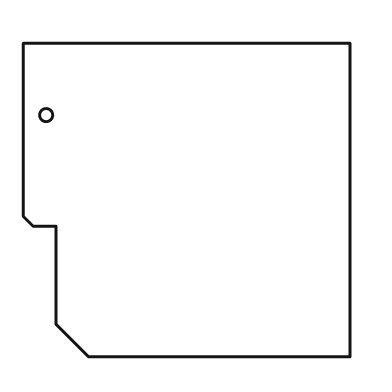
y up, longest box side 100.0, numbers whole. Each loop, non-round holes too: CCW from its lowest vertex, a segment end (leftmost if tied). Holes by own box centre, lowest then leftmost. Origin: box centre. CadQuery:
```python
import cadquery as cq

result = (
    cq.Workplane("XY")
    .moveTo(-30.0, -48.0)
    .lineTo(50.0, -48.0)
    .lineTo(50.0, 48.0)
    .lineTo(-50.0, 48.0)
    .lineTo(-50.0, -5.0)
    .lineTo(-47.0, -8.0)
    .lineTo(-40.0, -8.0)
    .lineTo(-40.0, -38.0)
    .close()
    .moveTo(-43.0, 26.0)
    .circle(2.0)
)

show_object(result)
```